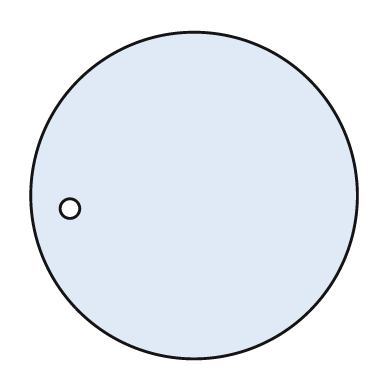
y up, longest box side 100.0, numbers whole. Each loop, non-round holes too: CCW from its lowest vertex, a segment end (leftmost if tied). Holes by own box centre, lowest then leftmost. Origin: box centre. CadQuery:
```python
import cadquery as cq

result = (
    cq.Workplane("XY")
    .moveTo(0.0, 0.0)
    .circle(50.0)
    .moveTo(-38.0, -4.0)
    .circle(3.0)
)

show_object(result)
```